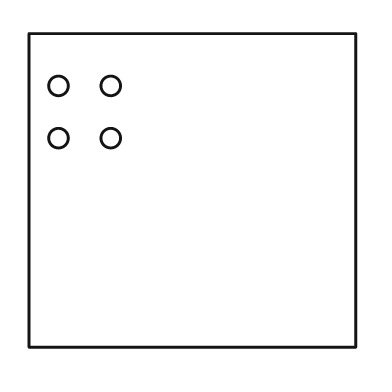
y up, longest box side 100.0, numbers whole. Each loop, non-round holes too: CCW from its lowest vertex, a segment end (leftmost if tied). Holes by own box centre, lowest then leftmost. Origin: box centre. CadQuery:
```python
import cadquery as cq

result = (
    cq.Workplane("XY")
    .moveTo(-50.0, -48.0)
    .lineTo(50.0, -48.0)
    .lineTo(50.0, 48.0)
    .lineTo(-50.0, 48.0)
    .close()
    .moveTo(-41.0, 16.0)
    .circle(3.0)
    .moveTo(-25.0, 16.0)
    .circle(3.0)
    .moveTo(-41.0, 32.0)
    .circle(3.0)
    .moveTo(-25.0, 32.0)
    .circle(3.0)
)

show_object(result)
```